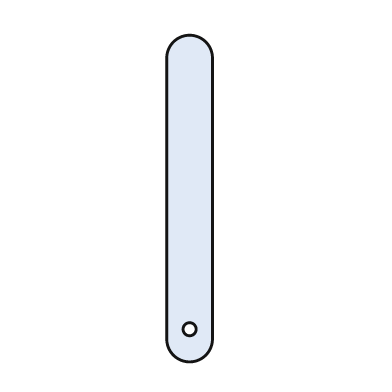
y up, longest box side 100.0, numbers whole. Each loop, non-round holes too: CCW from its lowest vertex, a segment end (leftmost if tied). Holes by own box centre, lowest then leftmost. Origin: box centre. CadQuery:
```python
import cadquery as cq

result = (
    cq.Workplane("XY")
    .moveTo(-7.0, -43.0)
    .threePointArc((0.0, -50.0), (7.0, -43.0))
    .lineTo(7.0, 43.0)
    .threePointArc((0.0, 50.0), (-7.0, 43.0))
    .close()
    .moveTo(0.0, -40.0)
    .circle(2.0)
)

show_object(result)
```